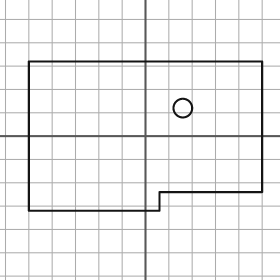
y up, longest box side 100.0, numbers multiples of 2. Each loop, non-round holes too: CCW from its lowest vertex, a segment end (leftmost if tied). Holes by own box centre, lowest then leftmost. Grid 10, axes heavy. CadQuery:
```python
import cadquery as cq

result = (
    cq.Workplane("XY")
    .moveTo(-50.0, -32.0)
    .lineTo(6.0, -32.0)
    .lineTo(6.0, -24.0)
    .lineTo(50.0, -24.0)
    .lineTo(50.0, 32.0)
    .lineTo(-50.0, 32.0)
    .close()
    .moveTo(16.0, 12.0)
    .circle(4.0)
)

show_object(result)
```